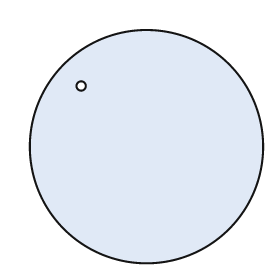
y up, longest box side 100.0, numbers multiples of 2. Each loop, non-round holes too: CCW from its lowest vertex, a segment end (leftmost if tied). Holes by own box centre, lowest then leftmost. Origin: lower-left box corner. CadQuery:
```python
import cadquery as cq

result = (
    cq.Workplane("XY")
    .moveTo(50.0, 50.0)
    .circle(50.0)
    .moveTo(22.0, 76.0)
    .circle(2.0)
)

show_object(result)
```